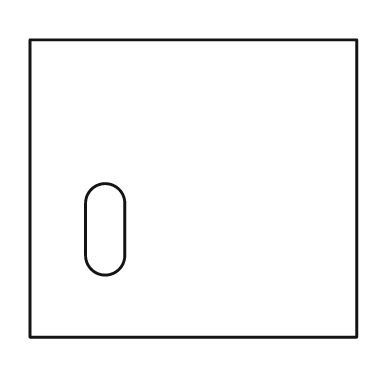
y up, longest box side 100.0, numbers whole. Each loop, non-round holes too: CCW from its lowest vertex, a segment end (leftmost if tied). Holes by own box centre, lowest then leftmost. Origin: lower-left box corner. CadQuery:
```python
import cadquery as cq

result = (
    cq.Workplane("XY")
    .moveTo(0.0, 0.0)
    .lineTo(100.0, 0.0)
    .lineTo(100.0, 91.0)
    .lineTo(0.0, 91.0)
    .close()
    .moveTo(17.0, 25.0)
    .threePointArc((23.0, 19.0), (29.0, 25.0))
    .lineTo(29.0, 41.0)
    .threePointArc((23.0, 47.0), (17.0, 41.0))
    .close()
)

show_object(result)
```